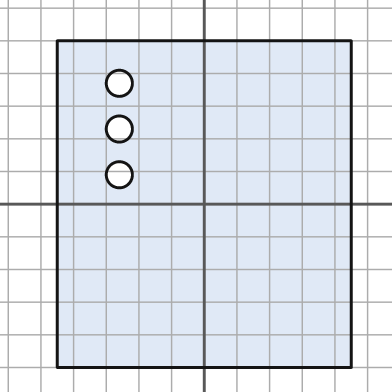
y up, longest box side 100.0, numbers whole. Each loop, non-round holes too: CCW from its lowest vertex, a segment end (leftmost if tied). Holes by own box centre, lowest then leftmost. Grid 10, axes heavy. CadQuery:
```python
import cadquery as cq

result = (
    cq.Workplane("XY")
    .moveTo(-45.0, -50.0)
    .lineTo(45.0, -50.0)
    .lineTo(45.0, 50.0)
    .lineTo(-45.0, 50.0)
    .close()
    .moveTo(-26.0, 9.0)
    .circle(4.0)
    .moveTo(-26.0, 23.0)
    .circle(4.0)
    .moveTo(-26.0, 37.0)
    .circle(4.0)
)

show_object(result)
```